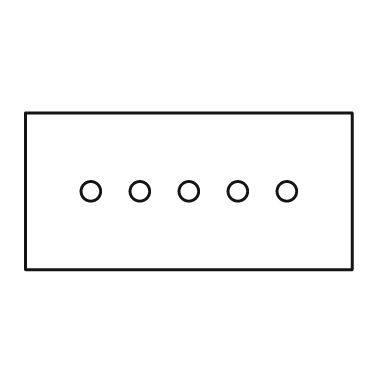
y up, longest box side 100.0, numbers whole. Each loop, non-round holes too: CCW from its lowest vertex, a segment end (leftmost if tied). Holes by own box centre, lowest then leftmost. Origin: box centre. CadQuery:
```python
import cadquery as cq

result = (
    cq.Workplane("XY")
    .moveTo(-50.0, -24.0)
    .lineTo(50.0, -24.0)
    .lineTo(50.0, 24.0)
    .lineTo(-50.0, 24.0)
    .close()
    .moveTo(-30.0, 0.0)
    .circle(3.0)
    .moveTo(-15.0, 0.0)
    .circle(3.0)
    .moveTo(0.0, 0.0)
    .circle(3.0)
    .moveTo(15.0, 0.0)
    .circle(3.0)
    .moveTo(30.0, 0.0)
    .circle(3.0)
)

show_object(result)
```